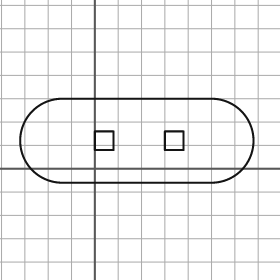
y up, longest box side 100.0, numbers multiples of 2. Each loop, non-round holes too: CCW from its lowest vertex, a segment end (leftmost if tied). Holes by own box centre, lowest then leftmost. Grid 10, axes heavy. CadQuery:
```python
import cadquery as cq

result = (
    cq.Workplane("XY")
    .moveTo(-14.0, -6.0)
    .lineTo(50.0, -6.0)
    .threePointArc((68.0, 12.0), (50.0, 30.0))
    .lineTo(-14.0, 30.0)
    .threePointArc((-32.0, 12.0), (-14.0, -6.0))
    .close()
    .moveTo(0.0, 8.0)
    .lineTo(8.0, 8.0)
    .lineTo(8.0, 16.0)
    .lineTo(0.0, 16.0)
    .close()
    .moveTo(30.0, 8.0)
    .lineTo(38.0, 8.0)
    .lineTo(38.0, 16.0)
    .lineTo(30.0, 16.0)
    .close()
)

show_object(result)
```